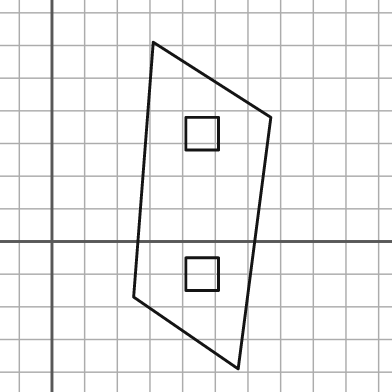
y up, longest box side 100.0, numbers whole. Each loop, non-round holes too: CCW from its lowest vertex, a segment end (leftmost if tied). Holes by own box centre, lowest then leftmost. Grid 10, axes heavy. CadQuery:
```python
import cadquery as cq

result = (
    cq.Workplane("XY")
    .moveTo(57.0, -39.0)
    .lineTo(67.0, 38.0)
    .lineTo(31.0, 61.0)
    .lineTo(25.0, -17.0)
    .close()
    .moveTo(41.0, -15.0)
    .lineTo(51.0, -15.0)
    .lineTo(51.0, -5.0)
    .lineTo(41.0, -5.0)
    .close()
    .moveTo(41.0, 28.0)
    .lineTo(51.0, 28.0)
    .lineTo(51.0, 38.0)
    .lineTo(41.0, 38.0)
    .close()
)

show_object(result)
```